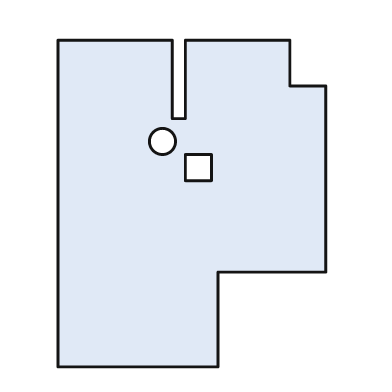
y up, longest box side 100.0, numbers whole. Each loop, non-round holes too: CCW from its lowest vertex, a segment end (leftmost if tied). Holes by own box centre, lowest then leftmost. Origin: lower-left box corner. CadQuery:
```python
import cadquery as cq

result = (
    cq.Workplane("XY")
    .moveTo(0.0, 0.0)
    .lineTo(49.0, 0.0)
    .lineTo(49.0, 29.0)
    .lineTo(82.0, 29.0)
    .lineTo(82.0, 86.0)
    .lineTo(71.0, 86.0)
    .lineTo(71.0, 100.0)
    .lineTo(39.0, 100.0)
    .lineTo(39.0, 76.0)
    .lineTo(35.0, 76.0)
    .lineTo(35.0, 100.0)
    .lineTo(0.0, 100.0)
    .close()
    .moveTo(39.0, 57.0)
    .lineTo(47.0, 57.0)
    .lineTo(47.0, 65.0)
    .lineTo(39.0, 65.0)
    .close()
    .moveTo(32.0, 69.0)
    .circle(4.0)
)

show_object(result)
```